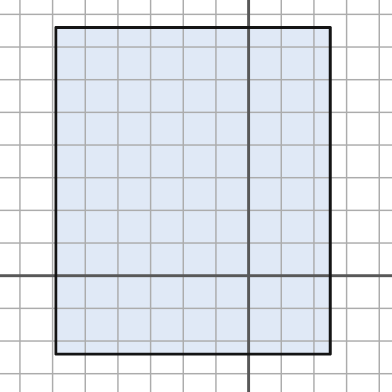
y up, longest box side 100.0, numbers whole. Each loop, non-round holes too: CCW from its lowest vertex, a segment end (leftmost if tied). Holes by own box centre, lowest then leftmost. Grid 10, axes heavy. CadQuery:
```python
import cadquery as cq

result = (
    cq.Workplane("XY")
    .moveTo(-59.0, -24.0)
    .lineTo(25.0, -24.0)
    .lineTo(25.0, 76.0)
    .lineTo(-59.0, 76.0)
    .close()
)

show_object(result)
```